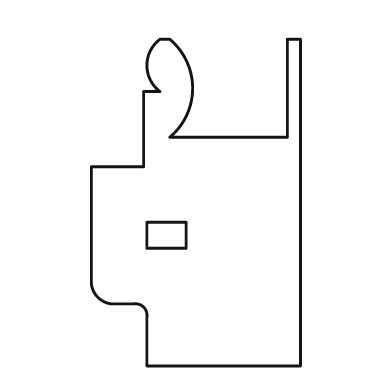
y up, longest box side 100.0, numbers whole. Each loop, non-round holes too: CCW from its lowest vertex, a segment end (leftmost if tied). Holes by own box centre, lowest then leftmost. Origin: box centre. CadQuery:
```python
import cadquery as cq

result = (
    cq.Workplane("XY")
    .moveTo(-15.0, -50.0)
    .lineTo(32.0, -50.0)
    .lineTo(32.0, 50.0)
    .lineTo(28.0, 50.0)
    .lineTo(28.0, 20.0)
    .lineTo(-8.0, 20.0)
    .threePointArc((-1.0, 35.0), (-8.0, 50.0))
    .lineTo(-11.0, 50.0)
    .threePointArc((-15.0, 42.0), (-11.0, 34.0))
    .lineTo(-16.0, 34.0)
    .lineTo(-16.0, 11.0)
    .lineTo(-32.0, 11.0)
    .lineTo(-32.0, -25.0)
    .threePointArc((-30.0, -29.0), (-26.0, -31.0))
    .lineTo(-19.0, -31.0)
    .threePointArc((-16.0, -32.0), (-15.0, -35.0))
    .close()
    .moveTo(-15.0, -14.0)
    .lineTo(-3.0, -14.0)
    .lineTo(-3.0, -6.0)
    .lineTo(-15.0, -6.0)
    .close()
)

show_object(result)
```